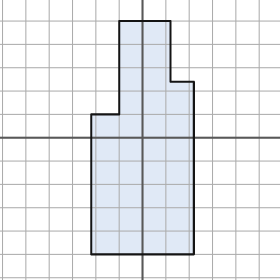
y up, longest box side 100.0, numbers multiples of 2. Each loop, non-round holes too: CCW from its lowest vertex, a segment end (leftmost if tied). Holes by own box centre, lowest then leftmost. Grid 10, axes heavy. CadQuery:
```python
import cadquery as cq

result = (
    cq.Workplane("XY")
    .moveTo(-22.0, -50.0)
    .lineTo(22.0, -50.0)
    .lineTo(22.0, 24.0)
    .lineTo(12.0, 24.0)
    .lineTo(12.0, 50.0)
    .lineTo(-10.0, 50.0)
    .lineTo(-10.0, 10.0)
    .lineTo(-22.0, 10.0)
    .close()
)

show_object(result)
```